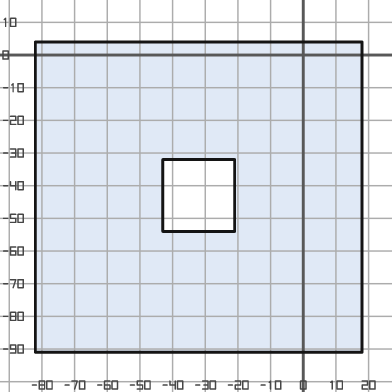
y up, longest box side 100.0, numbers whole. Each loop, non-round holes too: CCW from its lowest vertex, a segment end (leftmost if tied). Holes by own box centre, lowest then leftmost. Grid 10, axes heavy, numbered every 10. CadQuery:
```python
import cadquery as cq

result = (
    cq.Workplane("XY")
    .moveTo(-82.0, -91.0)
    .lineTo(18.0, -91.0)
    .lineTo(18.0, 4.0)
    .lineTo(-82.0, 4.0)
    .close()
    .moveTo(-43.0, -54.0)
    .lineTo(-21.0, -54.0)
    .lineTo(-21.0, -32.0)
    .lineTo(-43.0, -32.0)
    .close()
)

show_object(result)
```